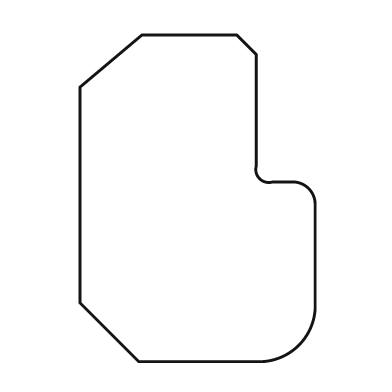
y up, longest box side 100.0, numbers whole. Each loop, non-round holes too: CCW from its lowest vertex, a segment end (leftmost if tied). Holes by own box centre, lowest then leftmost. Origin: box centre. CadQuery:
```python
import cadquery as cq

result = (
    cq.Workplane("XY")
    .moveTo(-18.0, -50.0)
    .lineTo(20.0, -50.0)
    .threePointArc((31.0, -45.0), (36.0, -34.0))
    .lineTo(36.0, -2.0)
    .threePointArc((34.0, 3.0), (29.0, 5.0))
    .lineTo(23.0, 5.0)
    .threePointArc((19.0, 6.0), (18.0, 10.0))
    .lineTo(18.0, 44.0)
    .lineTo(12.0, 50.0)
    .lineTo(-17.0, 50.0)
    .lineTo(-36.0, 34.0)
    .lineTo(-36.0, -32.0)
    .close()
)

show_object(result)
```